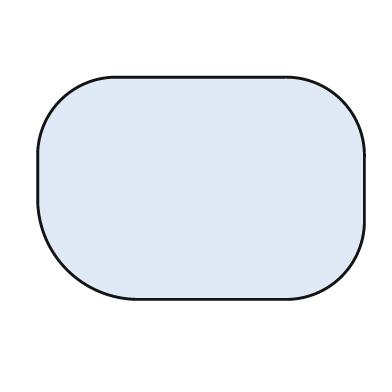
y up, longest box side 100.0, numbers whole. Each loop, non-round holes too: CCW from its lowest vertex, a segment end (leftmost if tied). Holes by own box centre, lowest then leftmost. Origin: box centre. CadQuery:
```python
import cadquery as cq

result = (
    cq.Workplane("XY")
    .moveTo(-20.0, -34.0)
    .lineTo(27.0, -34.0)
    .threePointArc((43.0, -27.0), (50.0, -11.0))
    .lineTo(50.0, 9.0)
    .threePointArc((43.0, 27.0), (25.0, 34.0))
    .lineTo(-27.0, 34.0)
    .threePointArc((-43.0, 27.0), (-50.0, 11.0))
    .lineTo(-50.0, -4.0)
    .threePointArc((-41.0, -25.0), (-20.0, -34.0))
    .close()
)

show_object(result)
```